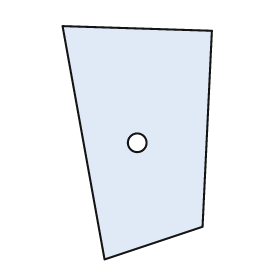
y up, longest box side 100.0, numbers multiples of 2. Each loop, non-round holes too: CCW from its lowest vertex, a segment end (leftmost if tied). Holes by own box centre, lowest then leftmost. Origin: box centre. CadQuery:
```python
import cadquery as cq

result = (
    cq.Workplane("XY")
    .moveTo(-14.0, -50.0)
    .lineTo(28.0, -36.0)
    .lineTo(32.0, 48.0)
    .lineTo(-32.0, 50.0)
    .close()
    .moveTo(0.0, 0.0)
    .circle(4.0)
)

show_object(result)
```